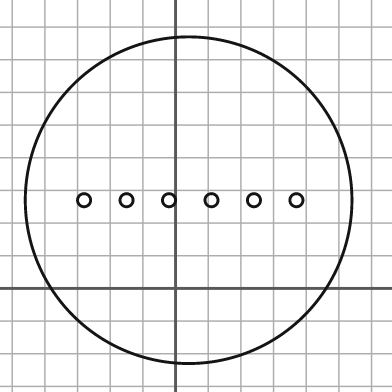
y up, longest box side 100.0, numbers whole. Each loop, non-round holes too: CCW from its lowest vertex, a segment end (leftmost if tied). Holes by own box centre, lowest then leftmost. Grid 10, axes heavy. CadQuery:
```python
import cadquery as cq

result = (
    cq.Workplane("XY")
    .moveTo(4.0, 27.0)
    .circle(50.0)
    .moveTo(-28.0, 27.0)
    .circle(2.0)
    .moveTo(-15.0, 27.0)
    .circle(2.0)
    .moveTo(-2.0, 27.0)
    .circle(2.0)
    .moveTo(11.0, 27.0)
    .circle(2.0)
    .moveTo(24.0, 27.0)
    .circle(2.0)
    .moveTo(37.0, 27.0)
    .circle(2.0)
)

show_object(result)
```